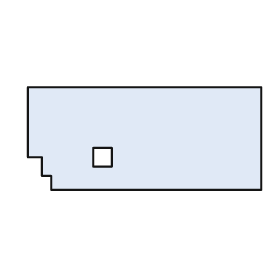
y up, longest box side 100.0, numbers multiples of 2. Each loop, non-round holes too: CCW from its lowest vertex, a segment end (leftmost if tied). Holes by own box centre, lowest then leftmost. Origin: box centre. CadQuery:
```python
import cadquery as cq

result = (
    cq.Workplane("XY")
    .moveTo(-40.0, -22.0)
    .lineTo(50.0, -22.0)
    .lineTo(50.0, 22.0)
    .lineTo(-50.0, 22.0)
    .lineTo(-50.0, -8.0)
    .lineTo(-44.0, -8.0)
    .lineTo(-44.0, -16.0)
    .lineTo(-40.0, -16.0)
    .close()
    .moveTo(-22.0, -12.0)
    .lineTo(-14.0, -12.0)
    .lineTo(-14.0, -4.0)
    .lineTo(-22.0, -4.0)
    .close()
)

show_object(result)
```